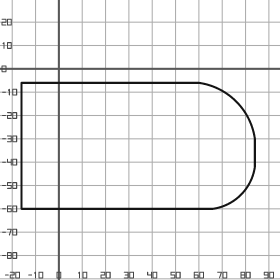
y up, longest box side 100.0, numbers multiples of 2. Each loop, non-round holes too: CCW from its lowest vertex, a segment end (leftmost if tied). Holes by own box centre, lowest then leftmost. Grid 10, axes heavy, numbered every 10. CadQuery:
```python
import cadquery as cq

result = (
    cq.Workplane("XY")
    .moveTo(-16.0, -60.0)
    .lineTo(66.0, -60.0)
    .threePointArc((78.0, -54.0), (84.0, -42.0))
    .lineTo(84.0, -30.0)
    .threePointArc((76.0, -14.0), (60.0, -6.0))
    .lineTo(-16.0, -6.0)
    .close()
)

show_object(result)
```